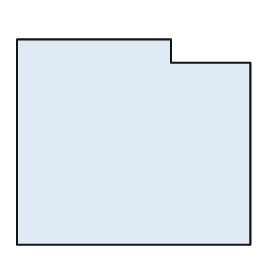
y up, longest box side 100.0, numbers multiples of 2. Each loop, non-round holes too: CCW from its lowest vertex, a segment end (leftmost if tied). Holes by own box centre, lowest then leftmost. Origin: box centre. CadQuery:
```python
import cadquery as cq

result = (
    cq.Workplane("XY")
    .moveTo(-50.0, -44.0)
    .lineTo(50.0, -44.0)
    .lineTo(50.0, 34.0)
    .lineTo(16.0, 34.0)
    .lineTo(16.0, 44.0)
    .lineTo(-50.0, 44.0)
    .close()
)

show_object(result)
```